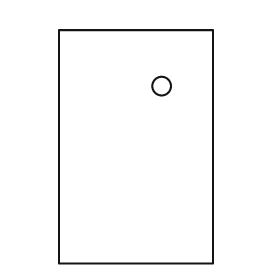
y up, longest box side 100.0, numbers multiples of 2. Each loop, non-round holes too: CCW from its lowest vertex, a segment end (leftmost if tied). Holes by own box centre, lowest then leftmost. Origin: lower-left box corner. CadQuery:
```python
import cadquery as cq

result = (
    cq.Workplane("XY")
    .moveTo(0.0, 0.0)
    .lineTo(66.0, 0.0)
    .lineTo(66.0, 100.0)
    .lineTo(0.0, 100.0)
    .close()
    .moveTo(44.0, 76.0)
    .circle(4.0)
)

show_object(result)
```